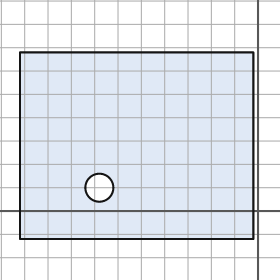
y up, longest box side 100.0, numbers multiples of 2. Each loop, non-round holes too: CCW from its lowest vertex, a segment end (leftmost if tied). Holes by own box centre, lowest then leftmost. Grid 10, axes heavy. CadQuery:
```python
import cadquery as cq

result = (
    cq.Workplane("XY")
    .moveTo(-102.0, -12.0)
    .lineTo(-2.0, -12.0)
    .lineTo(-2.0, 68.0)
    .lineTo(-102.0, 68.0)
    .close()
    .moveTo(-68.0, 10.0)
    .circle(6.0)
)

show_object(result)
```